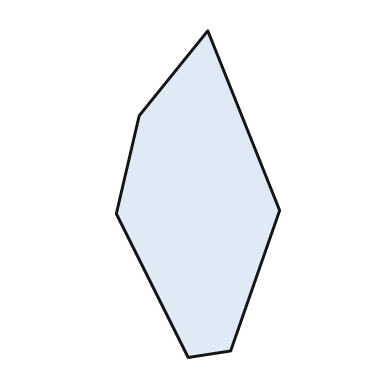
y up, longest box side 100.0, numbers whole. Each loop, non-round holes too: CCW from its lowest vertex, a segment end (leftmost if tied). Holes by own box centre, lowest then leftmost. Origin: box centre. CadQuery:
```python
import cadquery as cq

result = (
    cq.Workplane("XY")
    .moveTo(-3.0, -50.0)
    .lineTo(10.0, -48.0)
    .lineTo(25.0, -5.0)
    .lineTo(3.0, 50.0)
    .lineTo(-18.0, 24.0)
    .lineTo(-25.0, -6.0)
    .close()
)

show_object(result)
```